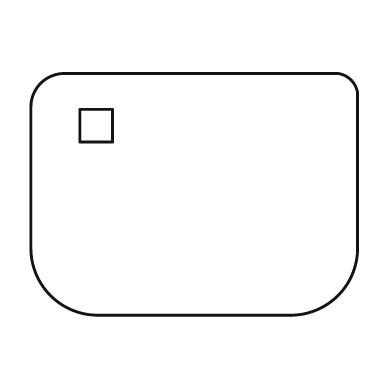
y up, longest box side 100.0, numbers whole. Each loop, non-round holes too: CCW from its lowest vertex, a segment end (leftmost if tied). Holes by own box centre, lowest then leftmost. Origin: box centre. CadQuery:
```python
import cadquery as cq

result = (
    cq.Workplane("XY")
    .moveTo(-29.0, -37.0)
    .lineTo(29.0, -37.0)
    .threePointArc((44.0, -31.0), (50.0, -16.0))
    .lineTo(50.0, 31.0)
    .threePointArc((48.0, 35.0), (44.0, 37.0))
    .lineTo(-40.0, 37.0)
    .threePointArc((-47.0, 34.0), (-50.0, 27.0))
    .lineTo(-50.0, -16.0)
    .threePointArc((-44.0, -31.0), (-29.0, -37.0))
    .close()
    .moveTo(-35.0, 16.0)
    .lineTo(-25.0, 16.0)
    .lineTo(-25.0, 26.0)
    .lineTo(-35.0, 26.0)
    .close()
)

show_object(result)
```